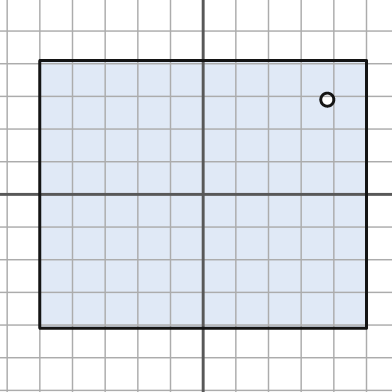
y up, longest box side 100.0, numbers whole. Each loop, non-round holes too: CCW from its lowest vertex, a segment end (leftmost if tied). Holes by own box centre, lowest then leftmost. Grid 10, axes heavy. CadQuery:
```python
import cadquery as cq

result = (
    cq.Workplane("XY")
    .moveTo(-50.0, -41.0)
    .lineTo(50.0, -41.0)
    .lineTo(50.0, 41.0)
    .lineTo(-50.0, 41.0)
    .close()
    .moveTo(38.0, 29.0)
    .circle(2.0)
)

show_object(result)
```